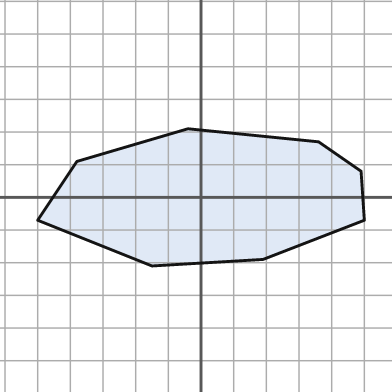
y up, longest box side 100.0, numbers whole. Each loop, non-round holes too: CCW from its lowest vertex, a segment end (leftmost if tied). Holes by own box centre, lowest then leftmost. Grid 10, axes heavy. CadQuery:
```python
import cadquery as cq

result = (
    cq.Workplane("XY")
    .moveTo(-15.0, -21.0)
    .lineTo(19.0, -19.0)
    .lineTo(50.0, -7.0)
    .lineTo(49.0, 8.0)
    .lineTo(36.0, 17.0)
    .lineTo(-4.0, 21.0)
    .lineTo(-38.0, 11.0)
    .lineTo(-50.0, -7.0)
    .close()
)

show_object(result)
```